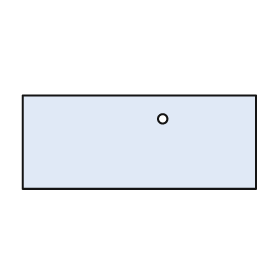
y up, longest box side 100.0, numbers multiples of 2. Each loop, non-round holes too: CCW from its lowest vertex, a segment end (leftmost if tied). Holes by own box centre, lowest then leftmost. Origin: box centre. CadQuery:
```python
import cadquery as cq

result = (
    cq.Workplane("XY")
    .moveTo(-50.0, -20.0)
    .lineTo(50.0, -20.0)
    .lineTo(50.0, 20.0)
    .lineTo(-50.0, 20.0)
    .close()
    .moveTo(10.0, 10.0)
    .circle(2.0)
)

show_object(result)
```